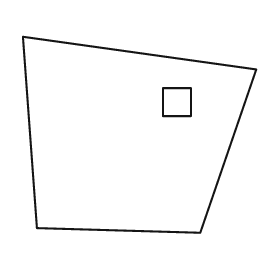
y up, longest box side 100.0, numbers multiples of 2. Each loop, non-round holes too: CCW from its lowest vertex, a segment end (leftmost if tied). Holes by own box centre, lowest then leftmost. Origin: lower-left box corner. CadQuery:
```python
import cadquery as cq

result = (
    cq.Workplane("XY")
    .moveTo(76.0, 0.0)
    .lineTo(100.0, 70.0)
    .lineTo(0.0, 84.0)
    .lineTo(6.0, 2.0)
    .close()
    .moveTo(60.0, 50.0)
    .lineTo(72.0, 50.0)
    .lineTo(72.0, 62.0)
    .lineTo(60.0, 62.0)
    .close()
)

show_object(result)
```